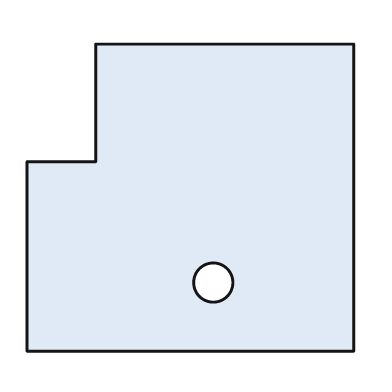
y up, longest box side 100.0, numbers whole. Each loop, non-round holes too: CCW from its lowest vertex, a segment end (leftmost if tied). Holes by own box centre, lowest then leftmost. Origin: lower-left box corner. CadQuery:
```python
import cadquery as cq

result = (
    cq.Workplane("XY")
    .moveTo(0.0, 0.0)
    .lineTo(100.0, 0.0)
    .lineTo(100.0, 94.0)
    .lineTo(21.0, 94.0)
    .lineTo(21.0, 58.0)
    .lineTo(0.0, 58.0)
    .close()
    .moveTo(57.0, 21.0)
    .circle(6.0)
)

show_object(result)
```